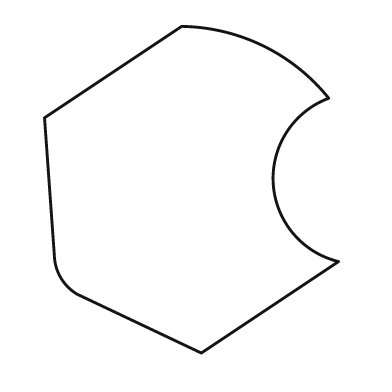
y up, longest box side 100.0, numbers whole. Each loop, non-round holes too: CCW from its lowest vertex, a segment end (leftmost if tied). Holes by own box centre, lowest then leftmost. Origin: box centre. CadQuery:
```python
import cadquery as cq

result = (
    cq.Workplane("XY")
    .moveTo(3.0, -50.0)
    .lineTo(45.0, -22.0)
    .threePointArc((25.0, 2.0), (42.0, 28.0))
    .threePointArc((22.0, 44.0), (-3.0, 50.0))
    .lineTo(-45.0, 22.0)
    .lineTo(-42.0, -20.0)
    .threePointArc((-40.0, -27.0), (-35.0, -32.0))
    .close()
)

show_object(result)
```